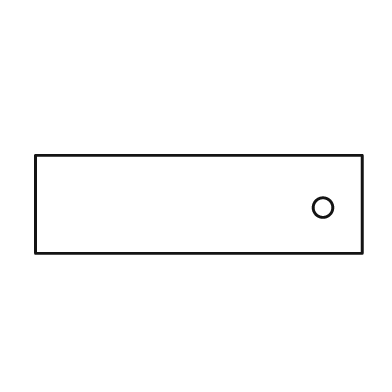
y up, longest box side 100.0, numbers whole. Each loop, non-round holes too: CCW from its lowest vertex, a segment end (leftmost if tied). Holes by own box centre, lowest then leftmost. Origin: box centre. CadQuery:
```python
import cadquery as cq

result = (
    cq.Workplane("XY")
    .moveTo(-50.0, -15.0)
    .lineTo(50.0, -15.0)
    .lineTo(50.0, 15.0)
    .lineTo(-50.0, 15.0)
    .close()
    .moveTo(38.0, -1.0)
    .circle(3.0)
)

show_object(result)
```